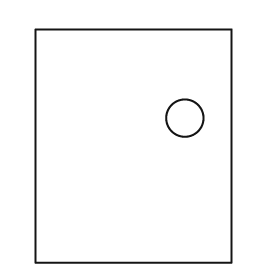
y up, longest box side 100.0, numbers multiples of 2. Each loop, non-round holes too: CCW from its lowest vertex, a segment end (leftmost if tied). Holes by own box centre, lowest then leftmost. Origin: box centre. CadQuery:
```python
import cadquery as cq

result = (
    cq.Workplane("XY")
    .moveTo(-42.0, -50.0)
    .lineTo(42.0, -50.0)
    .lineTo(42.0, 50.0)
    .lineTo(-42.0, 50.0)
    .close()
    .moveTo(22.0, 12.0)
    .circle(8.0)
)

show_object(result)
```